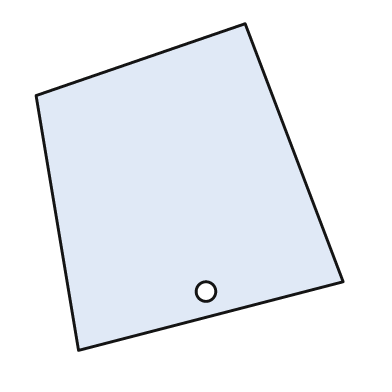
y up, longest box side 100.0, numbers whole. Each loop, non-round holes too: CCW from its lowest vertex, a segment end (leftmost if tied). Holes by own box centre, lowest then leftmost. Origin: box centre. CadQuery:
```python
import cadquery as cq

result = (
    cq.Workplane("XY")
    .moveTo(-34.0, -50.0)
    .lineTo(47.0, -29.0)
    .lineTo(17.0, 50.0)
    .lineTo(-47.0, 28.0)
    .close()
    .moveTo(5.0, -32.0)
    .circle(3.0)
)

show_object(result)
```